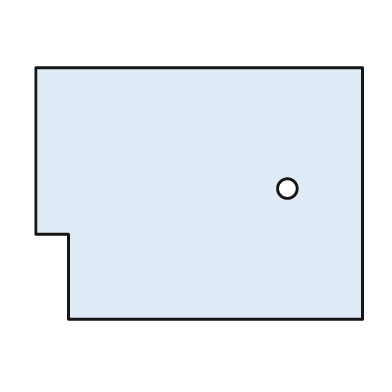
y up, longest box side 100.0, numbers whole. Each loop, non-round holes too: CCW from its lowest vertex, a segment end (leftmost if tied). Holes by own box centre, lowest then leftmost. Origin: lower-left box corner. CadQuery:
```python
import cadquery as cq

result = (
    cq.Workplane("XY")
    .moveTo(10.0, 0.0)
    .lineTo(100.0, 0.0)
    .lineTo(100.0, 77.0)
    .lineTo(0.0, 77.0)
    .lineTo(0.0, 26.0)
    .lineTo(10.0, 26.0)
    .close()
    .moveTo(77.0, 40.0)
    .circle(3.0)
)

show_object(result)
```